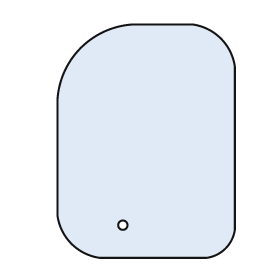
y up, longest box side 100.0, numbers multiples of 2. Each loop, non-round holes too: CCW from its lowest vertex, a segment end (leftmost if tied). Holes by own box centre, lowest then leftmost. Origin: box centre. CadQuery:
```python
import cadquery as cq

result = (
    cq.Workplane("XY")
    .moveTo(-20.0, -50.0)
    .lineTo(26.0, -50.0)
    .threePointArc((34.0, -46.0), (38.0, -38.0))
    .lineTo(38.0, 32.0)
    .threePointArc((32.0, 44.0), (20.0, 50.0))
    .lineTo(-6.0, 50.0)
    .threePointArc((-28.0, 40.0), (-38.0, 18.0))
    .lineTo(-38.0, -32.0)
    .threePointArc((-32.0, -44.0), (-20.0, -50.0))
    .close()
    .moveTo(-10.0, -36.0)
    .circle(2.0)
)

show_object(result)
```